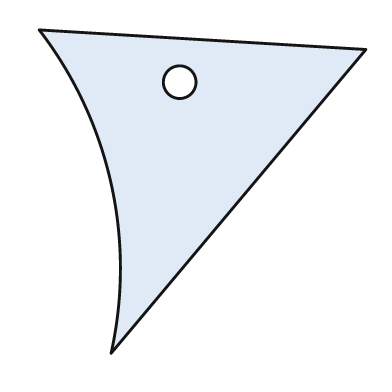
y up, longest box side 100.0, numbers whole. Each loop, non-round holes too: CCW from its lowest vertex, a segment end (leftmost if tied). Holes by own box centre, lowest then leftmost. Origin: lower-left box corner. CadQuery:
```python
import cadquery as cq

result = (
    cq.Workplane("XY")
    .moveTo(22.0, 0.0)
    .lineTo(100.0, 93.0)
    .lineTo(0.0, 99.0)
    .threePointArc((22.0, 52.0), (22.0, 0.0))
    .close()
    .moveTo(43.0, 83.0)
    .circle(5.0)
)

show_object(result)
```